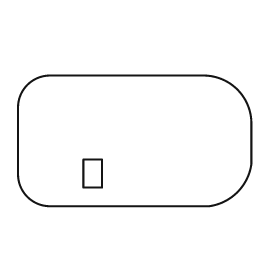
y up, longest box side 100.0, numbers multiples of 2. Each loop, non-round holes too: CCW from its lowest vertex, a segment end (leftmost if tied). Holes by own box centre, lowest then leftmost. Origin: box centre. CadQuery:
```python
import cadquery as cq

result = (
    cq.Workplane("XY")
    .moveTo(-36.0, -28.0)
    .lineTo(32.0, -28.0)
    .threePointArc((44.0, -22.0), (50.0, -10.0))
    .lineTo(50.0, 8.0)
    .threePointArc((44.0, 22.0), (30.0, 28.0))
    .lineTo(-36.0, 28.0)
    .threePointArc((-46.0, 24.0), (-50.0, 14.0))
    .lineTo(-50.0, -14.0)
    .threePointArc((-46.0, -24.0), (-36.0, -28.0))
    .close()
    .moveTo(-22.0, -20.0)
    .lineTo(-14.0, -20.0)
    .lineTo(-14.0, -8.0)
    .lineTo(-22.0, -8.0)
    .close()
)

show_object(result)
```